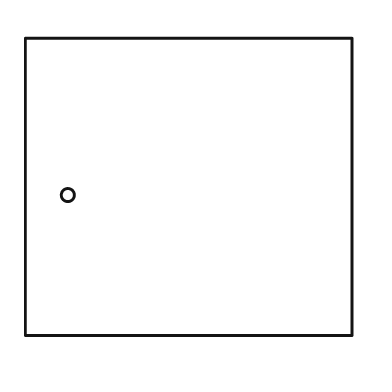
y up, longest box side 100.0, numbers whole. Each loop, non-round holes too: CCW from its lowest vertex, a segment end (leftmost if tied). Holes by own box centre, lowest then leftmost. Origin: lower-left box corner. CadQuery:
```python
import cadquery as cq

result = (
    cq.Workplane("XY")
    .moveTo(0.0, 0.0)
    .lineTo(100.0, 0.0)
    .lineTo(100.0, 91.0)
    .lineTo(0.0, 91.0)
    .close()
    .moveTo(13.0, 43.0)
    .circle(2.0)
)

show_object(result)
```